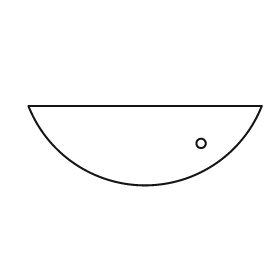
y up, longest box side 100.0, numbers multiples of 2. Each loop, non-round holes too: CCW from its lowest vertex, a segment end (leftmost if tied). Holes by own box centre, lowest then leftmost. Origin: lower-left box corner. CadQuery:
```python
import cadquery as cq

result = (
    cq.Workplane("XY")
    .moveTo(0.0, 34.0)
    .threePointArc((50.0, 0.0), (100.0, 34.0))
    .close()
    .moveTo(74.0, 18.0)
    .circle(2.0)
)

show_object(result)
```